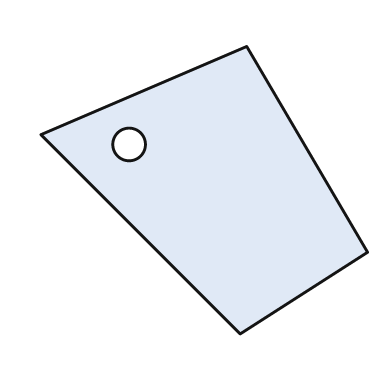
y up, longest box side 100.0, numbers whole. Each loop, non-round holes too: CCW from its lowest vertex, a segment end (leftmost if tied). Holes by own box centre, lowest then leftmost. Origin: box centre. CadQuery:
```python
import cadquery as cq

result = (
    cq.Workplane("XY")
    .moveTo(11.0, -44.0)
    .lineTo(50.0, -19.0)
    .lineTo(13.0, 44.0)
    .lineTo(-50.0, 17.0)
    .close()
    .moveTo(-23.0, 14.0)
    .circle(5.0)
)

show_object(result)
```